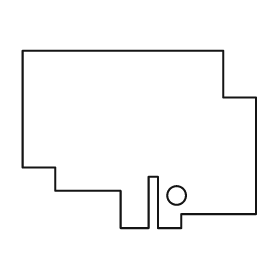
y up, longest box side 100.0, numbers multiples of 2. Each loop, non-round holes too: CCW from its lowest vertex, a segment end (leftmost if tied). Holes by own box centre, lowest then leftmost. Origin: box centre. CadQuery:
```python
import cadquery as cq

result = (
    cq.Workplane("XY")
    .moveTo(-8.0, -38.0)
    .lineTo(4.0, -38.0)
    .lineTo(4.0, -16.0)
    .lineTo(8.0, -16.0)
    .lineTo(8.0, -38.0)
    .lineTo(18.0, -38.0)
    .lineTo(18.0, -32.0)
    .lineTo(50.0, -32.0)
    .lineTo(50.0, 18.0)
    .lineTo(36.0, 18.0)
    .lineTo(36.0, 38.0)
    .lineTo(-50.0, 38.0)
    .lineTo(-50.0, -12.0)
    .lineTo(-36.0, -12.0)
    .lineTo(-36.0, -22.0)
    .lineTo(-8.0, -22.0)
    .close()
    .moveTo(16.0, -24.0)
    .circle(4.0)
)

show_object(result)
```